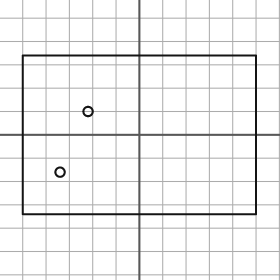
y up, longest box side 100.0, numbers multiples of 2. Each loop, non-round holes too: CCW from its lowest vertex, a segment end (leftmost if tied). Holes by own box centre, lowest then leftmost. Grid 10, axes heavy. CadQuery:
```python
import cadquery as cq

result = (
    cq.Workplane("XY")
    .moveTo(-50.0, -34.0)
    .lineTo(50.0, -34.0)
    .lineTo(50.0, 34.0)
    .lineTo(-50.0, 34.0)
    .close()
    .moveTo(-34.0, -16.0)
    .circle(2.0)
    .moveTo(-22.0, 10.0)
    .circle(2.0)
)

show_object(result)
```